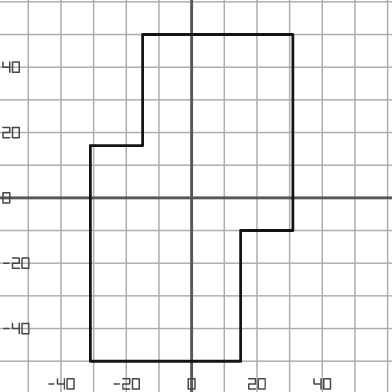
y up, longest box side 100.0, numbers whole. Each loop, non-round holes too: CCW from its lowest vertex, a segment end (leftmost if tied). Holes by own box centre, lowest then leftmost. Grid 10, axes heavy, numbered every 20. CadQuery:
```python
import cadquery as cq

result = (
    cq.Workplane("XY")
    .moveTo(-31.0, -50.0)
    .lineTo(15.0, -50.0)
    .lineTo(15.0, -10.0)
    .lineTo(31.0, -10.0)
    .lineTo(31.0, 50.0)
    .lineTo(-15.0, 50.0)
    .lineTo(-15.0, 16.0)
    .lineTo(-31.0, 16.0)
    .close()
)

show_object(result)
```